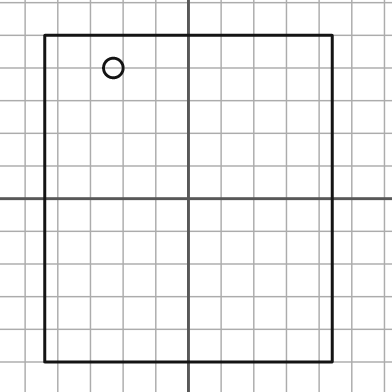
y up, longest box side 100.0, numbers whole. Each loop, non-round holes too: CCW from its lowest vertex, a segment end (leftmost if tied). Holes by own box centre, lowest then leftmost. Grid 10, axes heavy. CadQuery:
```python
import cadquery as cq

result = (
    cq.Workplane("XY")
    .moveTo(-44.0, -50.0)
    .lineTo(44.0, -50.0)
    .lineTo(44.0, 50.0)
    .lineTo(-44.0, 50.0)
    .close()
    .moveTo(-23.0, 40.0)
    .circle(3.0)
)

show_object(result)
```